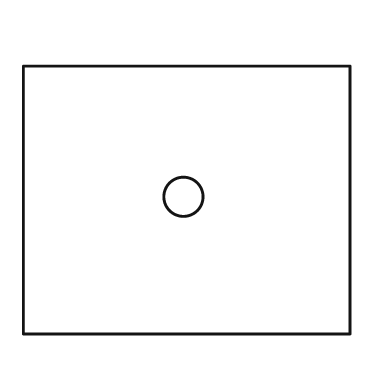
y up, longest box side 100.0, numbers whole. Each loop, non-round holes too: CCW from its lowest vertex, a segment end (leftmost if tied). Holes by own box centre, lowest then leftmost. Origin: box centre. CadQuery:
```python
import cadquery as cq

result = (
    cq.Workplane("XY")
    .moveTo(-50.0, -41.0)
    .lineTo(50.0, -41.0)
    .lineTo(50.0, 41.0)
    .lineTo(-50.0, 41.0)
    .close()
    .moveTo(-1.0, 1.0)
    .circle(6.0)
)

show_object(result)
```